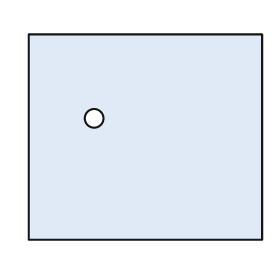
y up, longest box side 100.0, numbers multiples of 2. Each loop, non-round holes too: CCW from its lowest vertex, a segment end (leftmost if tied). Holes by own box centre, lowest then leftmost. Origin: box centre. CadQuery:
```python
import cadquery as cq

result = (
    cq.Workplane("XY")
    .moveTo(-50.0, -44.0)
    .lineTo(50.0, -44.0)
    .lineTo(50.0, 44.0)
    .lineTo(-50.0, 44.0)
    .close()
    .moveTo(-22.0, 8.0)
    .circle(4.0)
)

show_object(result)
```